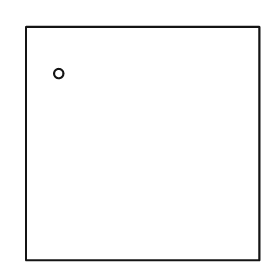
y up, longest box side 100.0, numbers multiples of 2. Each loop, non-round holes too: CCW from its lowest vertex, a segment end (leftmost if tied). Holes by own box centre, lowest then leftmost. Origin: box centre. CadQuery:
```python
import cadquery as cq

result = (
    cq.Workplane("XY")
    .moveTo(-50.0, -50.0)
    .lineTo(50.0, -50.0)
    .lineTo(50.0, 50.0)
    .lineTo(-50.0, 50.0)
    .close()
    .moveTo(-36.0, 30.0)
    .circle(2.0)
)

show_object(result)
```